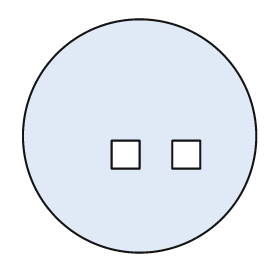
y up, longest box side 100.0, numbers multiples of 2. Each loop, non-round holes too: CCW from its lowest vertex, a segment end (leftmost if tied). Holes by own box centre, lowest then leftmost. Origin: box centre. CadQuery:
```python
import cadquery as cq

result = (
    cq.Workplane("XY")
    .moveTo(0.0, 0.0)
    .circle(50.0)
    .moveTo(-12.0, -14.0)
    .lineTo(0.0, -14.0)
    .lineTo(0.0, -2.0)
    .lineTo(-12.0, -2.0)
    .close()
    .moveTo(14.0, -14.0)
    .lineTo(26.0, -14.0)
    .lineTo(26.0, -2.0)
    .lineTo(14.0, -2.0)
    .close()
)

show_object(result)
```